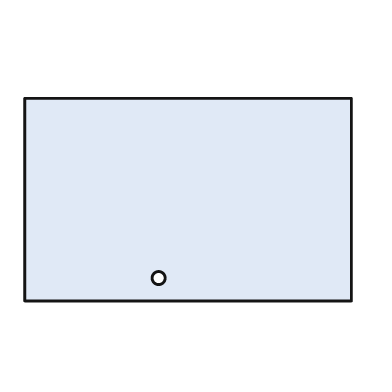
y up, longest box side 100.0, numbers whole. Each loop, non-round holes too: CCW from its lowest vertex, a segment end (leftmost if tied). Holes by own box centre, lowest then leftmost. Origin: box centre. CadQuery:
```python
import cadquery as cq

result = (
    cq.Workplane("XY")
    .moveTo(-50.0, -31.0)
    .lineTo(50.0, -31.0)
    .lineTo(50.0, 31.0)
    .lineTo(-50.0, 31.0)
    .close()
    .moveTo(-9.0, -24.0)
    .circle(2.0)
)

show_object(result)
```